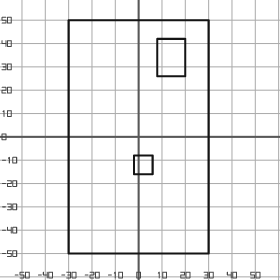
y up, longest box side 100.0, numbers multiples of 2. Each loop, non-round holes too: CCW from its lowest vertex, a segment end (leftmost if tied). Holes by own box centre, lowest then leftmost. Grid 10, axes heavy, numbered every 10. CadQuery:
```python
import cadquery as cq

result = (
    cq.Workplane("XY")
    .moveTo(-30.0, -50.0)
    .lineTo(30.0, -50.0)
    .lineTo(30.0, 50.0)
    .lineTo(-30.0, 50.0)
    .close()
    .moveTo(-2.0, -16.0)
    .lineTo(6.0, -16.0)
    .lineTo(6.0, -8.0)
    .lineTo(-2.0, -8.0)
    .close()
    .moveTo(8.0, 26.0)
    .lineTo(20.0, 26.0)
    .lineTo(20.0, 42.0)
    .lineTo(8.0, 42.0)
    .close()
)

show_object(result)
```